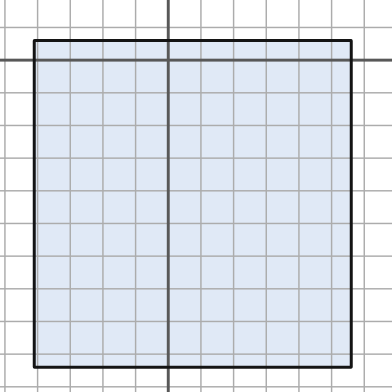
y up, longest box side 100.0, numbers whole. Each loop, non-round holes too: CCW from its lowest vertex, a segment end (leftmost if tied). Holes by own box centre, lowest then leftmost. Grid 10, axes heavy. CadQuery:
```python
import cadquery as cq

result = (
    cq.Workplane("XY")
    .moveTo(-41.0, -94.0)
    .lineTo(56.0, -94.0)
    .lineTo(56.0, 6.0)
    .lineTo(-41.0, 6.0)
    .close()
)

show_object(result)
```